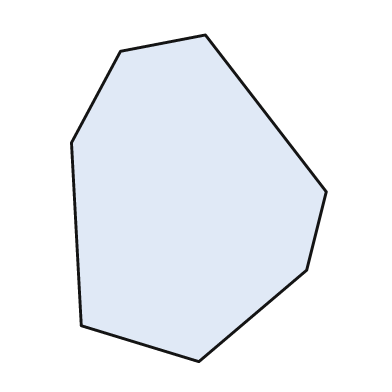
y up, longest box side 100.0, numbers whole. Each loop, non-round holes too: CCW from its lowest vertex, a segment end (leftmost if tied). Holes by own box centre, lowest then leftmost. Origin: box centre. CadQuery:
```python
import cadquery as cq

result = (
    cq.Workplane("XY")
    .moveTo(0.0, -50.0)
    .lineTo(33.0, -22.0)
    .lineTo(39.0, 2.0)
    .lineTo(2.0, 50.0)
    .lineTo(-24.0, 45.0)
    .lineTo(-39.0, 17.0)
    .lineTo(-36.0, -39.0)
    .close()
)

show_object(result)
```